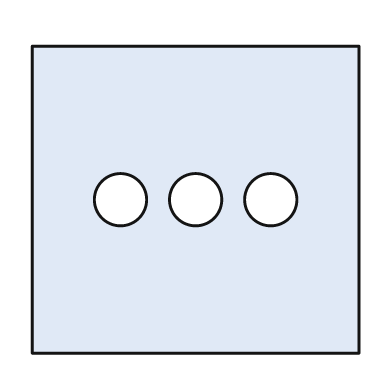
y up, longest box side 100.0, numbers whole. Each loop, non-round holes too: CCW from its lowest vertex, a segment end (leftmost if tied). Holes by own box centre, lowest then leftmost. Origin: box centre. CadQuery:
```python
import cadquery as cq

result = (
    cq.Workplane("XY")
    .moveTo(-50.0, -47.0)
    .lineTo(50.0, -47.0)
    .lineTo(50.0, 47.0)
    .lineTo(-50.0, 47.0)
    .close()
    .moveTo(-23.0, 0.0)
    .circle(8.0)
    .moveTo(0.0, 0.0)
    .circle(8.0)
    .moveTo(23.0, 0.0)
    .circle(8.0)
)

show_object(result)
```